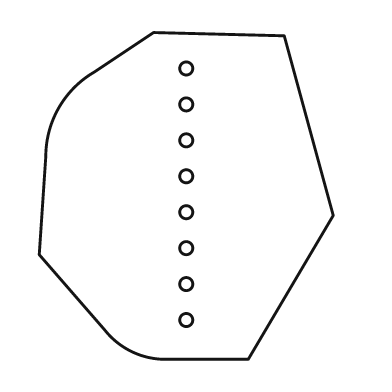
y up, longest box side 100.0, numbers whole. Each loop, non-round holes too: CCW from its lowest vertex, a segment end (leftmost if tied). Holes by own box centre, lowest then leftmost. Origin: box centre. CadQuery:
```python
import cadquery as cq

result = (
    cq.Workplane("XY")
    .moveTo(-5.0, -50.0)
    .lineTo(19.0, -50.0)
    .lineTo(45.0, -6.0)
    .lineTo(30.0, 49.0)
    .lineTo(-10.0, 50.0)
    .lineTo(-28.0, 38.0)
    .threePointArc((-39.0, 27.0), (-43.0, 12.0))
    .lineTo(-45.0, -18.0)
    .lineTo(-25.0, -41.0)
    .threePointArc((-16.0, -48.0), (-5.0, -50.0))
    .close()
    .moveTo(0.0, -38.0)
    .circle(2.0)
    .moveTo(0.0, -27.0)
    .circle(2.0)
    .moveTo(0.0, -16.0)
    .circle(2.0)
    .moveTo(0.0, -5.0)
    .circle(2.0)
    .moveTo(0.0, 6.0)
    .circle(2.0)
    .moveTo(0.0, 17.0)
    .circle(2.0)
    .moveTo(0.0, 28.0)
    .circle(2.0)
    .moveTo(0.0, 39.0)
    .circle(2.0)
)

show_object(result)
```